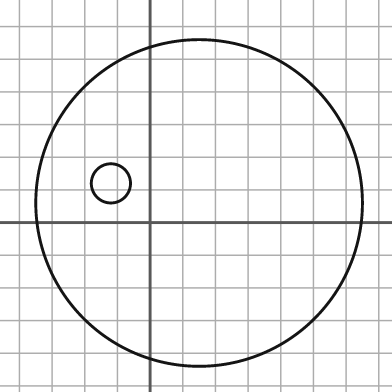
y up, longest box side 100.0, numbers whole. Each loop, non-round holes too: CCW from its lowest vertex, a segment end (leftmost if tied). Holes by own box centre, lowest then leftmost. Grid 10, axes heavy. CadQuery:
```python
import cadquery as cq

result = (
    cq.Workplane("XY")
    .moveTo(15.0, 6.0)
    .circle(50.0)
    .moveTo(-12.0, 12.0)
    .circle(6.0)
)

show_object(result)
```